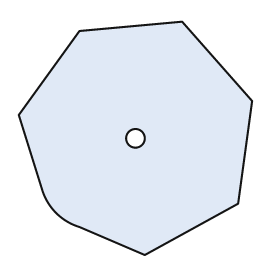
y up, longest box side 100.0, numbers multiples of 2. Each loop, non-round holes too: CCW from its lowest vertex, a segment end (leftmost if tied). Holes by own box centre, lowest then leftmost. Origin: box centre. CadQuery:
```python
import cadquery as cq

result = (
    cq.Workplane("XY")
    .moveTo(4.0, -50.0)
    .lineTo(44.0, -28.0)
    .lineTo(50.0, 16.0)
    .lineTo(20.0, 50.0)
    .lineTo(-24.0, 46.0)
    .lineTo(-50.0, 10.0)
    .lineTo(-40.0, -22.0)
    .threePointArc((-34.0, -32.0), (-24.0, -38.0))
    .close()
    .moveTo(0.0, 0.0)
    .circle(4.0)
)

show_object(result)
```